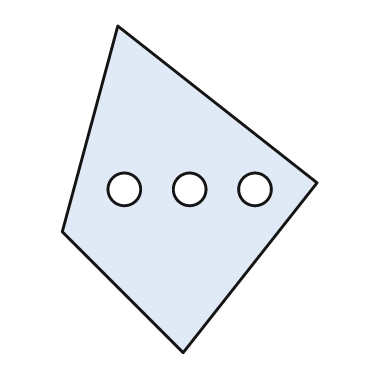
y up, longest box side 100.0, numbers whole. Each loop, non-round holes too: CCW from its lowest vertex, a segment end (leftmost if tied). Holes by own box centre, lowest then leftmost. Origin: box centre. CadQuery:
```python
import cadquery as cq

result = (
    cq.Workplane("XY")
    .moveTo(-2.0, -50.0)
    .lineTo(39.0, 2.0)
    .lineTo(-22.0, 50.0)
    .lineTo(-39.0, -13.0)
    .close()
    .moveTo(-20.0, 0.0)
    .circle(5.0)
    .moveTo(0.0, 0.0)
    .circle(5.0)
    .moveTo(20.0, 0.0)
    .circle(5.0)
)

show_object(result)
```